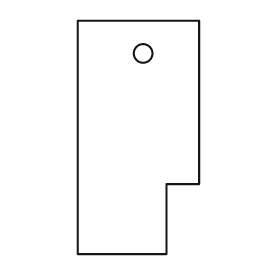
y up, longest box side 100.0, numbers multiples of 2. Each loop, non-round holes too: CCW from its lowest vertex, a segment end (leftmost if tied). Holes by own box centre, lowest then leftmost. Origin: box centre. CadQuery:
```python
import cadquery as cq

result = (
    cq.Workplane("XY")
    .moveTo(-26.0, -50.0)
    .lineTo(12.0, -50.0)
    .lineTo(12.0, -20.0)
    .lineTo(26.0, -20.0)
    .lineTo(26.0, 50.0)
    .lineTo(-26.0, 50.0)
    .close()
    .moveTo(2.0, 36.0)
    .circle(4.0)
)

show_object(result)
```